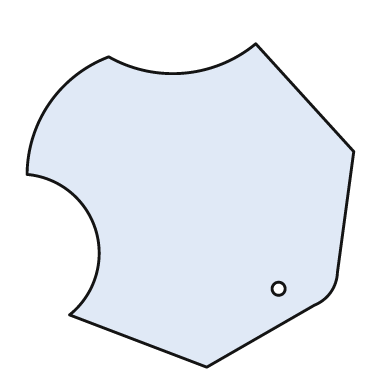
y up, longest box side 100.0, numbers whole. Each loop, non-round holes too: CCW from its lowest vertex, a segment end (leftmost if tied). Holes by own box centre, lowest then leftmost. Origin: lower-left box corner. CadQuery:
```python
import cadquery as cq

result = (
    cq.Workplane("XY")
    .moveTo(55.0, 0.0)
    .lineTo(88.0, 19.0)
    .threePointArc((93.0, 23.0), (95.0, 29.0))
    .lineTo(100.0, 66.0)
    .lineTo(70.0, 99.0)
    .threePointArc((48.0, 90.0), (25.0, 95.0))
    .threePointArc((7.0, 81.0), (0.0, 59.0))
    .threePointArc((21.0, 42.0), (13.0, 16.0))
    .close()
    .moveTo(77.0, 24.0)
    .circle(2.0)
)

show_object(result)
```